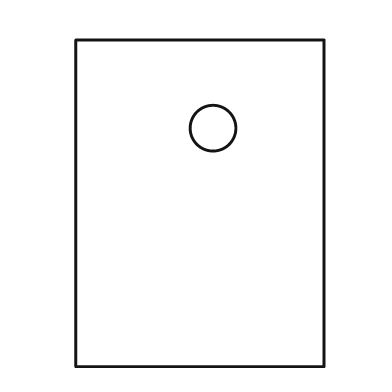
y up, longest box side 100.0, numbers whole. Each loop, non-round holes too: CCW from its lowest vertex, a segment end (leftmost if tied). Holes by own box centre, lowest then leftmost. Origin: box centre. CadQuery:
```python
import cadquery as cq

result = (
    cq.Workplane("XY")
    .moveTo(-38.0, -50.0)
    .lineTo(38.0, -50.0)
    .lineTo(38.0, 50.0)
    .lineTo(-38.0, 50.0)
    .close()
    .moveTo(4.0, 23.0)
    .circle(7.0)
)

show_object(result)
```